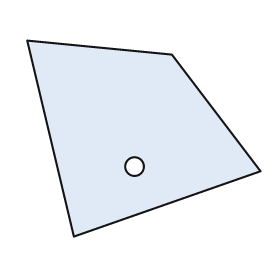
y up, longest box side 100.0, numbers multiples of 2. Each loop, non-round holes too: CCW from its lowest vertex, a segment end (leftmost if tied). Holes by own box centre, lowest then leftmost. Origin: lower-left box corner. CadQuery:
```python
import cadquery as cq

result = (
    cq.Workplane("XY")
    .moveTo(20.0, 0.0)
    .lineTo(100.0, 28.0)
    .lineTo(62.0, 78.0)
    .lineTo(0.0, 84.0)
    .close()
    .moveTo(46.0, 30.0)
    .circle(4.0)
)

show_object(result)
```